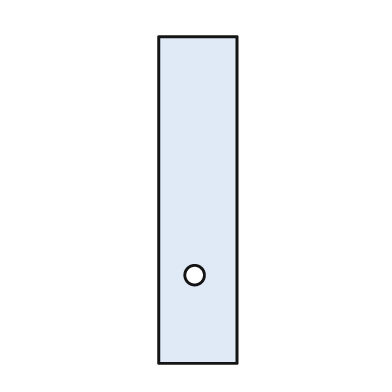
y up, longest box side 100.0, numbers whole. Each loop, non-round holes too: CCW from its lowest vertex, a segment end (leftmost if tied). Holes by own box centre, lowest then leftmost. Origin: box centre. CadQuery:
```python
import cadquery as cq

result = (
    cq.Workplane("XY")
    .moveTo(-12.0, -50.0)
    .lineTo(12.0, -50.0)
    .lineTo(12.0, 50.0)
    .lineTo(-12.0, 50.0)
    .close()
    .moveTo(-1.0, -23.0)
    .circle(3.0)
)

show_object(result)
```